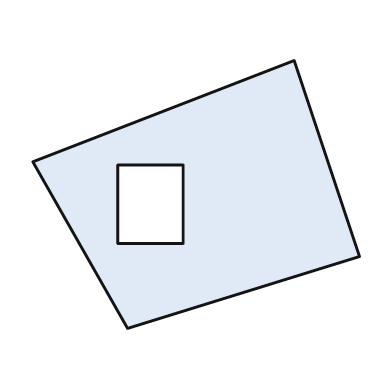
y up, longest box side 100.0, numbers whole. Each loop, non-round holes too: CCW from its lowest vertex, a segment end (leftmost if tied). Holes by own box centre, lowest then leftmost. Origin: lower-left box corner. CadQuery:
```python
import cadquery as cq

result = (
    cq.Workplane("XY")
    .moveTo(29.0, 0.0)
    .lineTo(100.0, 22.0)
    .lineTo(80.0, 82.0)
    .lineTo(0.0, 51.0)
    .close()
    .moveTo(26.0, 26.0)
    .lineTo(46.0, 26.0)
    .lineTo(46.0, 50.0)
    .lineTo(26.0, 50.0)
    .close()
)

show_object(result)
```